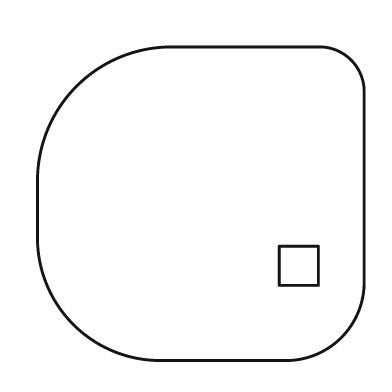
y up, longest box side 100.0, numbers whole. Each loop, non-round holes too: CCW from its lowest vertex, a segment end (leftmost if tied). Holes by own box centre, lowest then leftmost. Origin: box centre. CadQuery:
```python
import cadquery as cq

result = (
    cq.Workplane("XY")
    .moveTo(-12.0, -48.0)
    .lineTo(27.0, -48.0)
    .threePointArc((43.0, -41.0), (50.0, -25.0))
    .lineTo(50.0, 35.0)
    .threePointArc((46.0, 44.0), (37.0, 48.0))
    .lineTo(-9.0, 48.0)
    .threePointArc((-38.0, 36.0), (-50.0, 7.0))
    .lineTo(-50.0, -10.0)
    .threePointArc((-39.0, -37.0), (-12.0, -48.0))
    .close()
    .moveTo(24.0, -25.0)
    .lineTo(36.0, -25.0)
    .lineTo(36.0, -13.0)
    .lineTo(24.0, -13.0)
    .close()
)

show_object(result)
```